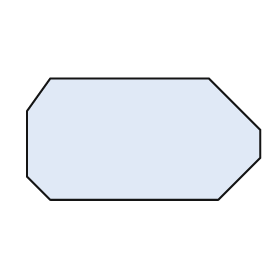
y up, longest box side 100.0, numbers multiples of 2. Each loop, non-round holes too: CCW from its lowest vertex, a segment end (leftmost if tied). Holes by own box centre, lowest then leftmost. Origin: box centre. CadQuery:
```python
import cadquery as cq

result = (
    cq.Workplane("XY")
    .moveTo(-40.0, -26.0)
    .lineTo(32.0, -26.0)
    .lineTo(50.0, -8.0)
    .lineTo(50.0, 4.0)
    .lineTo(28.0, 26.0)
    .lineTo(-40.0, 26.0)
    .lineTo(-50.0, 12.0)
    .lineTo(-50.0, -16.0)
    .close()
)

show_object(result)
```